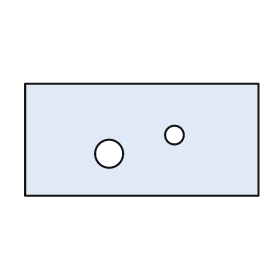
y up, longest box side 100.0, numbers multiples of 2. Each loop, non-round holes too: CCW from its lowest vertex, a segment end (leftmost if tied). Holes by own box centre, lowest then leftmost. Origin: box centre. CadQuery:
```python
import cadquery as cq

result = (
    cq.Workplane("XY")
    .moveTo(-50.0, -24.0)
    .lineTo(50.0, -24.0)
    .lineTo(50.0, 24.0)
    .lineTo(-50.0, 24.0)
    .close()
    .moveTo(-14.0, -6.0)
    .circle(6.0)
    .moveTo(14.0, 2.0)
    .circle(4.0)
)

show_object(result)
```